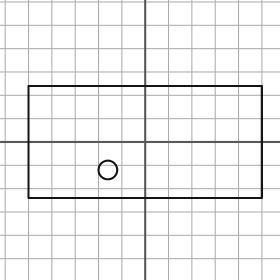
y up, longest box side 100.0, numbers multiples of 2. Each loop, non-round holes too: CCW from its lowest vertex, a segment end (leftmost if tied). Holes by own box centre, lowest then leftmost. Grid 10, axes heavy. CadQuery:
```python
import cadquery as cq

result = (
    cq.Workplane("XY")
    .moveTo(-50.0, -24.0)
    .lineTo(50.0, -24.0)
    .lineTo(50.0, 24.0)
    .lineTo(-50.0, 24.0)
    .close()
    .moveTo(-16.0, -12.0)
    .circle(4.0)
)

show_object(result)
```